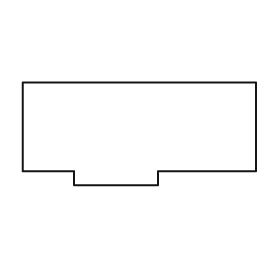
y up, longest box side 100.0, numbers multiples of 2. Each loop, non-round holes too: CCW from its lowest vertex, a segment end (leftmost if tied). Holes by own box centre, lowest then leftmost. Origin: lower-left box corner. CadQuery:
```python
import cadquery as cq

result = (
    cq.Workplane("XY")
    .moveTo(22.0, 0.0)
    .lineTo(58.0, 0.0)
    .lineTo(58.0, 6.0)
    .lineTo(100.0, 6.0)
    .lineTo(100.0, 44.0)
    .lineTo(0.0, 44.0)
    .lineTo(0.0, 6.0)
    .lineTo(22.0, 6.0)
    .close()
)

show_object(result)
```